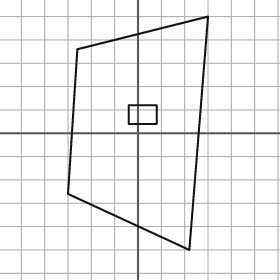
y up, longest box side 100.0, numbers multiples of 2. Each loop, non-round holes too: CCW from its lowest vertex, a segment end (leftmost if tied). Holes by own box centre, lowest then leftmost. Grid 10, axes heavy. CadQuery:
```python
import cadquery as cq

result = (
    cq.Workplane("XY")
    .moveTo(22.0, -50.0)
    .lineTo(30.0, 50.0)
    .lineTo(-26.0, 36.0)
    .lineTo(-30.0, -26.0)
    .close()
    .moveTo(-4.0, 4.0)
    .lineTo(8.0, 4.0)
    .lineTo(8.0, 12.0)
    .lineTo(-4.0, 12.0)
    .close()
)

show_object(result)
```